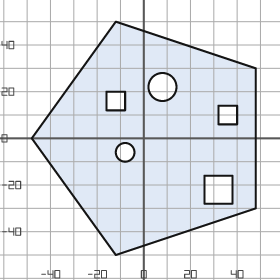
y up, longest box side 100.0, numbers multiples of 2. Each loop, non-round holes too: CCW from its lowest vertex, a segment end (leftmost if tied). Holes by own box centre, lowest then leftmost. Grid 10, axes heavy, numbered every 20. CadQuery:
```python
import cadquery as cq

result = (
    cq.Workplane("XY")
    .moveTo(-12.0, -50.0)
    .lineTo(48.0, -30.0)
    .lineTo(48.0, 30.0)
    .lineTo(-12.0, 50.0)
    .lineTo(-48.0, 0.0)
    .close()
    .moveTo(26.0, -28.0)
    .lineTo(38.0, -28.0)
    .lineTo(38.0, -16.0)
    .lineTo(26.0, -16.0)
    .close()
    .moveTo(-8.0, -6.0)
    .circle(4.0)
    .moveTo(32.0, 6.0)
    .lineTo(40.0, 6.0)
    .lineTo(40.0, 14.0)
    .lineTo(32.0, 14.0)
    .close()
    .moveTo(-16.0, 12.0)
    .lineTo(-8.0, 12.0)
    .lineTo(-8.0, 20.0)
    .lineTo(-16.0, 20.0)
    .close()
    .moveTo(8.0, 22.0)
    .circle(6.0)
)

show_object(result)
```